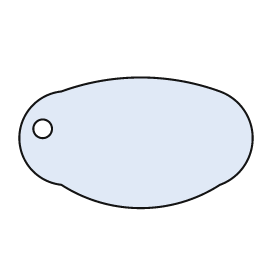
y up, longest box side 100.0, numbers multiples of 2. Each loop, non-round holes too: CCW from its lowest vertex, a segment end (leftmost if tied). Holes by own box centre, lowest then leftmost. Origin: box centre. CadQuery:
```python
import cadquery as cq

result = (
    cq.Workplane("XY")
    .moveTo(-32.0, -18.0)
    .threePointArc((2.0, -28.0), (36.0, -18.0))
    .threePointArc((50.0, 2.0), (36.0, 22.0))
    .threePointArc((2.0, 28.0), (-32.0, 22.0))
    .threePointArc((-50.0, 2.0), (-32.0, -18.0))
    .close()
    .moveTo(-40.0, 6.0)
    .circle(4.0)
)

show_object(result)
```